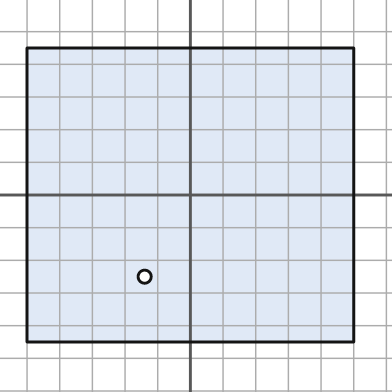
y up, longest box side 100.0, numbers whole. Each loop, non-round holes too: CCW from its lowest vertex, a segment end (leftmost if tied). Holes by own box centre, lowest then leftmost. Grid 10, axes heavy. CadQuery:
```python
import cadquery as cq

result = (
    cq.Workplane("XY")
    .moveTo(-50.0, -45.0)
    .lineTo(50.0, -45.0)
    .lineTo(50.0, 45.0)
    .lineTo(-50.0, 45.0)
    .close()
    .moveTo(-14.0, -25.0)
    .circle(2.0)
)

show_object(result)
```